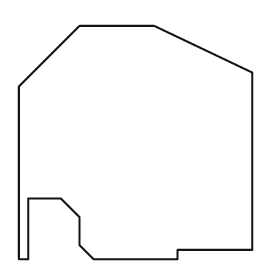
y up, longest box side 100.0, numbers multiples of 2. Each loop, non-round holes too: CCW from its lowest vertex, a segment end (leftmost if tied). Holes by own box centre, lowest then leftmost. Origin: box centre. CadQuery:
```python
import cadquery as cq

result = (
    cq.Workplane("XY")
    .moveTo(-50.0, -50.0)
    .lineTo(-46.0, -50.0)
    .lineTo(-46.0, -24.0)
    .lineTo(-32.0, -24.0)
    .lineTo(-24.0, -32.0)
    .lineTo(-24.0, -44.0)
    .lineTo(-18.0, -50.0)
    .lineTo(18.0, -50.0)
    .lineTo(18.0, -46.0)
    .lineTo(50.0, -46.0)
    .lineTo(50.0, 30.0)
    .lineTo(8.0, 50.0)
    .lineTo(-24.0, 50.0)
    .lineTo(-50.0, 24.0)
    .close()
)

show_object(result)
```